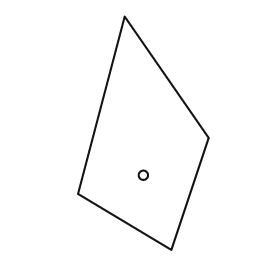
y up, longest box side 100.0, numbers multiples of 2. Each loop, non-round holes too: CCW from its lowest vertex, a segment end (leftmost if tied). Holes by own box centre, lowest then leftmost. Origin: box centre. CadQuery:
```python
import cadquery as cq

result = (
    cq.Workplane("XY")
    .moveTo(12.0, -50.0)
    .lineTo(28.0, -2.0)
    .lineTo(-8.0, 50.0)
    .lineTo(-28.0, -26.0)
    .close()
    .moveTo(0.0, -18.0)
    .circle(2.0)
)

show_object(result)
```